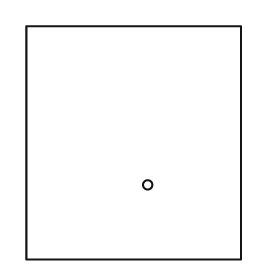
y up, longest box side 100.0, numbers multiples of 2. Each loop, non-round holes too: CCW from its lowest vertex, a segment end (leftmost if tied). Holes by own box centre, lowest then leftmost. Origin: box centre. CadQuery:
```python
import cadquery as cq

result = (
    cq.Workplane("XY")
    .moveTo(-46.0, -50.0)
    .lineTo(46.0, -50.0)
    .lineTo(46.0, 50.0)
    .lineTo(-46.0, 50.0)
    .close()
    .moveTo(6.0, -18.0)
    .circle(2.0)
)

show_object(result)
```